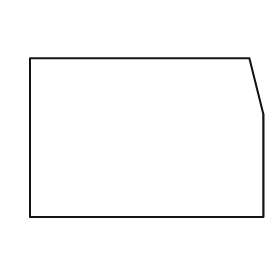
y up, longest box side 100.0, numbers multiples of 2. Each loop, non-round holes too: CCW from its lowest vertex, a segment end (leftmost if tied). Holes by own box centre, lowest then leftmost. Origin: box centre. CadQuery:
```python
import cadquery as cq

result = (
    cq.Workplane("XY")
    .moveTo(-50.0, -34.0)
    .lineTo(50.0, -34.0)
    .lineTo(50.0, 10.0)
    .lineTo(44.0, 34.0)
    .lineTo(-50.0, 34.0)
    .close()
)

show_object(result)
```